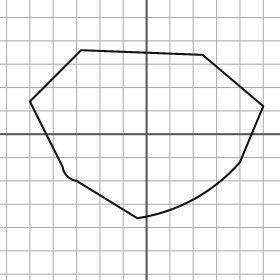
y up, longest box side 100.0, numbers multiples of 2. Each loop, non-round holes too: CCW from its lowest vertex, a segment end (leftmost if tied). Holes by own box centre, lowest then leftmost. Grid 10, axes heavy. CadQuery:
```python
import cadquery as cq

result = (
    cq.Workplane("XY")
    .moveTo(-4.0, -36.0)
    .threePointArc((20.0, -28.0), (40.0, -12.0))
    .lineTo(50.0, 12.0)
    .lineTo(24.0, 34.0)
    .lineTo(-28.0, 36.0)
    .lineTo(-50.0, 14.0)
    .lineTo(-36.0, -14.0)
    .threePointArc((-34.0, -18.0), (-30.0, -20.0))
    .close()
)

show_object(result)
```